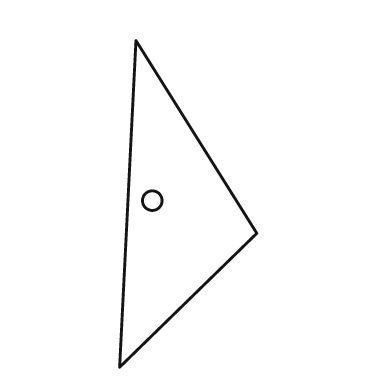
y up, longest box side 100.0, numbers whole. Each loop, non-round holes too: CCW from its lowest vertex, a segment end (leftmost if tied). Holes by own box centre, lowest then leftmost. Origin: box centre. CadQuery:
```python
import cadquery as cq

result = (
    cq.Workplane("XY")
    .moveTo(-21.0, -50.0)
    .lineTo(21.0, -9.0)
    .lineTo(-16.0, 50.0)
    .close()
    .moveTo(-11.0, 1.0)
    .circle(3.0)
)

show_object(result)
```